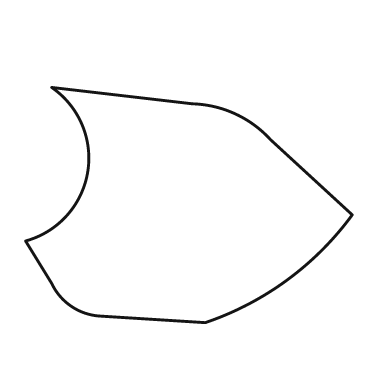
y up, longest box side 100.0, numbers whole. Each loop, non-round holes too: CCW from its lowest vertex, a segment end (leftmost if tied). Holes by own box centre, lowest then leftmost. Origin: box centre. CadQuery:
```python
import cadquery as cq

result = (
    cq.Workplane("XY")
    .moveTo(5.0, -36.0)
    .threePointArc((30.0, -23.0), (50.0, -3.0))
    .lineTo(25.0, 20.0)
    .threePointArc((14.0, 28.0), (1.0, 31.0))
    .lineTo(-42.0, 36.0)
    .threePointArc((-31.0, 10.0), (-50.0, -11.0))
    .lineTo(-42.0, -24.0)
    .threePointArc((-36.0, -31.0), (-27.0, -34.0))
    .close()
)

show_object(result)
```